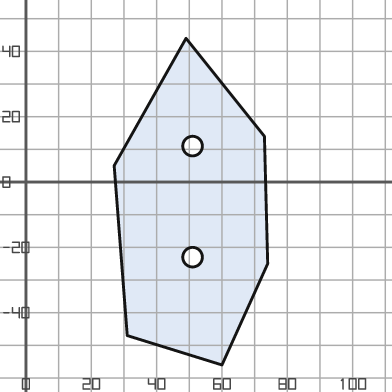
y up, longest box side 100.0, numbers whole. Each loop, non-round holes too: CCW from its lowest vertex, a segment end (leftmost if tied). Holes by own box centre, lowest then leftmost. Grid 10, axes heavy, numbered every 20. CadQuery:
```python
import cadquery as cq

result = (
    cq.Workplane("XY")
    .moveTo(60.0, -56.0)
    .lineTo(74.0, -25.0)
    .lineTo(73.0, 14.0)
    .lineTo(49.0, 44.0)
    .lineTo(27.0, 5.0)
    .lineTo(31.0, -47.0)
    .close()
    .moveTo(51.0, -23.0)
    .circle(3.0)
    .moveTo(51.0, 11.0)
    .circle(3.0)
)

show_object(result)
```